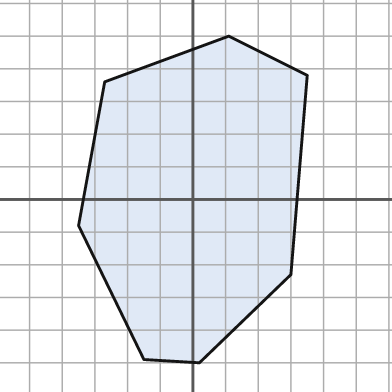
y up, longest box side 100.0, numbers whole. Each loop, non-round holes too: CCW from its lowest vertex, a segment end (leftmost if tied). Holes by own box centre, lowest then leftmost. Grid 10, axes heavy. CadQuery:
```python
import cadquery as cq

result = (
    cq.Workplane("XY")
    .moveTo(2.0, -50.0)
    .lineTo(30.0, -23.0)
    .lineTo(35.0, 38.0)
    .lineTo(11.0, 50.0)
    .lineTo(-27.0, 36.0)
    .lineTo(-35.0, -8.0)
    .lineTo(-15.0, -49.0)
    .close()
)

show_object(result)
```